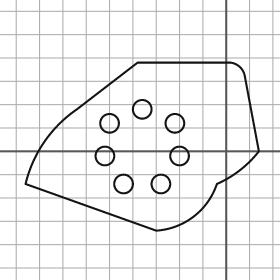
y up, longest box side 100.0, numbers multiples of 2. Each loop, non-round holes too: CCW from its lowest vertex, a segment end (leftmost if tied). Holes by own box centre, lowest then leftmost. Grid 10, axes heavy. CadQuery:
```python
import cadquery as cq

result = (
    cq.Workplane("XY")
    .moveTo(-30.0, -34.0)
    .threePointArc((-14.0, -28.0), (-4.0, -14.0))
    .threePointArc((6.0, -8.0), (14.0, 0.0))
    .lineTo(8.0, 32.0)
    .threePointArc((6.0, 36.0), (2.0, 38.0))
    .lineTo(-38.0, 38.0)
    .lineTo(-64.0, 18.0)
    .threePointArc((-78.0, 4.0), (-86.0, -14.0))
    .close()
    .moveTo(-44.0, -14.0)
    .circle(4.0)
    .moveTo(-28.0, -14.0)
    .circle(4.0)
    .moveTo(-52.0, -2.0)
    .circle(4.0)
    .moveTo(-20.0, -2.0)
    .circle(4.0)
    .moveTo(-50.0, 12.0)
    .circle(4.0)
    .moveTo(-22.0, 12.0)
    .circle(4.0)
    .moveTo(-36.0, 18.0)
    .circle(4.0)
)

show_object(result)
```